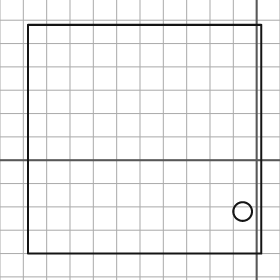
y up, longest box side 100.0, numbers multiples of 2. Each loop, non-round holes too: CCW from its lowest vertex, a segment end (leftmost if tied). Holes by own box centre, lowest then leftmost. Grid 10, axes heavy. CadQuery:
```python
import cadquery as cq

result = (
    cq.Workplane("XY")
    .moveTo(-98.0, -40.0)
    .lineTo(2.0, -40.0)
    .lineTo(2.0, 58.0)
    .lineTo(-98.0, 58.0)
    .close()
    .moveTo(-6.0, -22.0)
    .circle(4.0)
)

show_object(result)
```